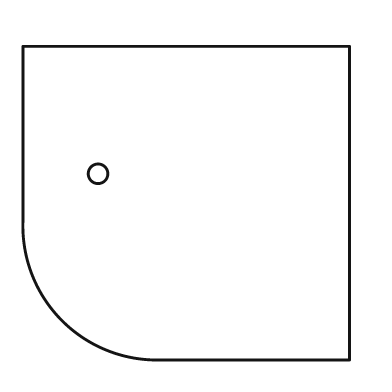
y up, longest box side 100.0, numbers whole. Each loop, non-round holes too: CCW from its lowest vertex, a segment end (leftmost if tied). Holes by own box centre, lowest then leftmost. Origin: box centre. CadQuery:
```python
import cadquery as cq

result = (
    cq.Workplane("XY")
    .moveTo(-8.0, -48.0)
    .lineTo(50.0, -48.0)
    .lineTo(50.0, 48.0)
    .lineTo(-50.0, 48.0)
    .lineTo(-50.0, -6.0)
    .threePointArc((-38.0, -36.0), (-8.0, -48.0))
    .close()
    .moveTo(-27.0, 9.0)
    .circle(3.0)
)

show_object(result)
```